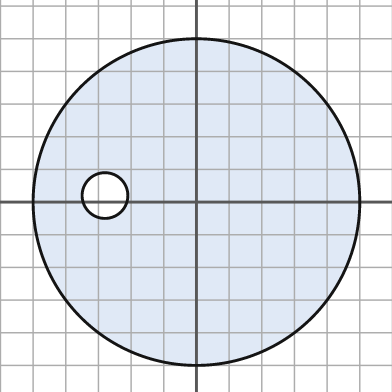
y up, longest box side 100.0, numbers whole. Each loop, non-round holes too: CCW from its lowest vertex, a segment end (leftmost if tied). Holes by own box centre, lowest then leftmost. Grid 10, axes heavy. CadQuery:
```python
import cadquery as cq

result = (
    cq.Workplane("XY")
    .moveTo(0.0, 0.0)
    .circle(50.0)
    .moveTo(-28.0, 2.0)
    .circle(7.0)
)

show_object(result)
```